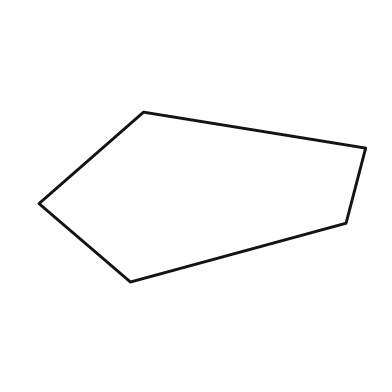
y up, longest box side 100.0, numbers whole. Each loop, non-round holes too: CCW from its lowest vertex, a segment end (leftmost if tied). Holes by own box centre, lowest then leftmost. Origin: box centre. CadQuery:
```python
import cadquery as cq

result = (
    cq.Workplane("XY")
    .moveTo(-22.0, -26.0)
    .lineTo(44.0, -8.0)
    .lineTo(50.0, 15.0)
    .lineTo(-18.0, 26.0)
    .lineTo(-50.0, -2.0)
    .close()
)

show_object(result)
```